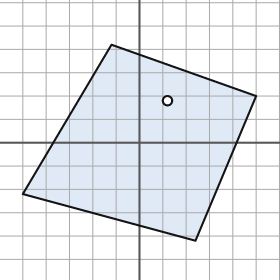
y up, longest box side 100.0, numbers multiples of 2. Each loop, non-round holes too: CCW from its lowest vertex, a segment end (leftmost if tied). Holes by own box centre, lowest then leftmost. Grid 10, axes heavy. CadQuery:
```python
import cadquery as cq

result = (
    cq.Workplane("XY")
    .moveTo(24.0, -42.0)
    .lineTo(50.0, 20.0)
    .lineTo(-12.0, 42.0)
    .lineTo(-50.0, -22.0)
    .close()
    .moveTo(12.0, 18.0)
    .circle(2.0)
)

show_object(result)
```